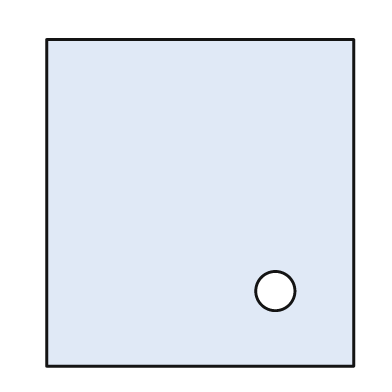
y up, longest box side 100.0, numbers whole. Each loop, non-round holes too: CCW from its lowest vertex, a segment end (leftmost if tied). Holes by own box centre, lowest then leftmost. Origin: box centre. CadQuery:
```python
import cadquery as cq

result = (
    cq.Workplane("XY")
    .moveTo(-47.0, -50.0)
    .lineTo(47.0, -50.0)
    .lineTo(47.0, 50.0)
    .lineTo(-47.0, 50.0)
    .close()
    .moveTo(23.0, -27.0)
    .circle(6.0)
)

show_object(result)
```